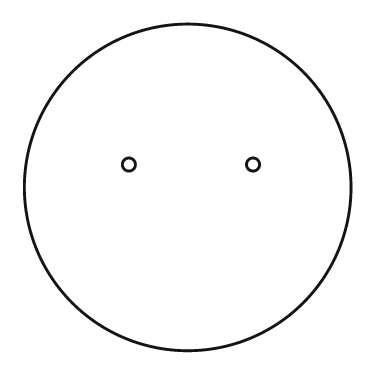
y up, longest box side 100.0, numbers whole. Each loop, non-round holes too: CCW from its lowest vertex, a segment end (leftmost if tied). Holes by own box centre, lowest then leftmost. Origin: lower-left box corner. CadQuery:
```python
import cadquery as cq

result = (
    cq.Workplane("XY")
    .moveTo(50.0, 50.0)
    .circle(50.0)
    .moveTo(32.0, 57.0)
    .circle(2.0)
    .moveTo(70.0, 57.0)
    .circle(2.0)
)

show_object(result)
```